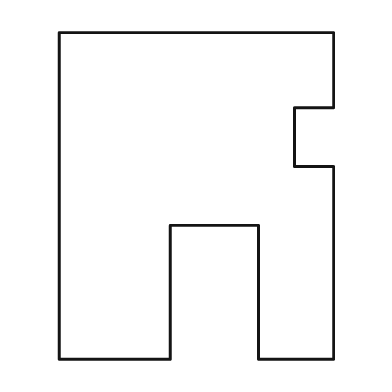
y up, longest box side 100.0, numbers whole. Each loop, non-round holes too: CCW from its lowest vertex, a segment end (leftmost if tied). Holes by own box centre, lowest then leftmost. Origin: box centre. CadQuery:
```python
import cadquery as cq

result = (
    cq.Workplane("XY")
    .moveTo(-42.0, -50.0)
    .lineTo(-8.0, -50.0)
    .lineTo(-8.0, -9.0)
    .lineTo(19.0, -9.0)
    .lineTo(19.0, -50.0)
    .lineTo(42.0, -50.0)
    .lineTo(42.0, 9.0)
    .lineTo(30.0, 9.0)
    .lineTo(30.0, 27.0)
    .lineTo(42.0, 27.0)
    .lineTo(42.0, 50.0)
    .lineTo(-42.0, 50.0)
    .close()
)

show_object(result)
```